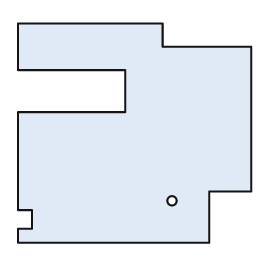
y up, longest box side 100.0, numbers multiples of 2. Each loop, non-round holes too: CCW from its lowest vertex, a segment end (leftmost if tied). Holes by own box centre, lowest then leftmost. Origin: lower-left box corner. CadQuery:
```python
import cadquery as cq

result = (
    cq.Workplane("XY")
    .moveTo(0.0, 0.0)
    .lineTo(82.0, 0.0)
    .lineTo(82.0, 22.0)
    .lineTo(100.0, 22.0)
    .lineTo(100.0, 84.0)
    .lineTo(62.0, 84.0)
    .lineTo(62.0, 94.0)
    .lineTo(0.0, 94.0)
    .lineTo(0.0, 74.0)
    .lineTo(46.0, 74.0)
    .lineTo(46.0, 56.0)
    .lineTo(0.0, 56.0)
    .lineTo(0.0, 14.0)
    .lineTo(6.0, 14.0)
    .lineTo(6.0, 6.0)
    .lineTo(0.0, 6.0)
    .close()
    .moveTo(66.0, 18.0)
    .circle(2.0)
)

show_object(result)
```